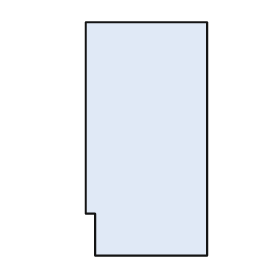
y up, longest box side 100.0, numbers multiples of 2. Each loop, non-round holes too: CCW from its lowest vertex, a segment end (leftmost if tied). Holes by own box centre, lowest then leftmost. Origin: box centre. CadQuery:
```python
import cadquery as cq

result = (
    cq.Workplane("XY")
    .moveTo(-22.0, -50.0)
    .lineTo(26.0, -50.0)
    .lineTo(26.0, 50.0)
    .lineTo(-26.0, 50.0)
    .lineTo(-26.0, -32.0)
    .lineTo(-22.0, -32.0)
    .close()
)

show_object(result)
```